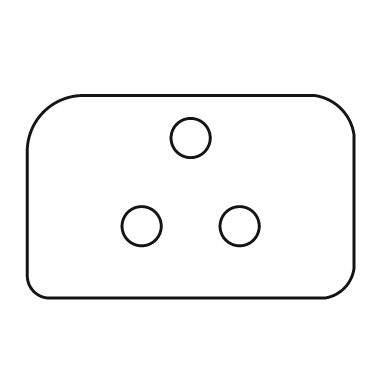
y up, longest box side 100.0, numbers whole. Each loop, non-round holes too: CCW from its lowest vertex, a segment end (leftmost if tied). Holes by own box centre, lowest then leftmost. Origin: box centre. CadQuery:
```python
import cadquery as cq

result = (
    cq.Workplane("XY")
    .moveTo(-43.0, -31.0)
    .lineTo(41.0, -31.0)
    .threePointArc((47.0, -28.0), (50.0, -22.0))
    .lineTo(50.0, 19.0)
    .threePointArc((46.0, 27.0), (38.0, 31.0))
    .lineTo(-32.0, 31.0)
    .threePointArc((-45.0, 26.0), (-50.0, 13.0))
    .lineTo(-50.0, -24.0)
    .threePointArc((-48.0, -29.0), (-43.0, -31.0))
    .close()
    .moveTo(-15.0, -9.0)
    .circle(6.0)
    .moveTo(15.0, -9.0)
    .circle(6.0)
    .moveTo(0.0, 18.0)
    .circle(6.0)
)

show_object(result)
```